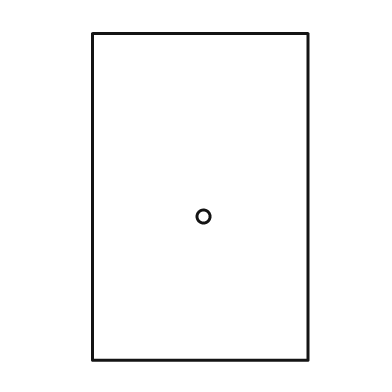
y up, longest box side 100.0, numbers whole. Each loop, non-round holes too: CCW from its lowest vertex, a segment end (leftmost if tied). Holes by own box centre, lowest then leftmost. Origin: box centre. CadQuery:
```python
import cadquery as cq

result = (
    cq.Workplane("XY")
    .moveTo(-33.0, -50.0)
    .lineTo(33.0, -50.0)
    .lineTo(33.0, 50.0)
    .lineTo(-33.0, 50.0)
    .close()
    .moveTo(1.0, -6.0)
    .circle(2.0)
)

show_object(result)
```